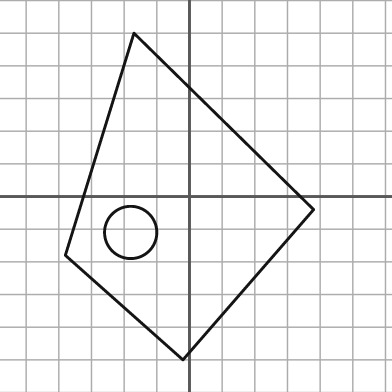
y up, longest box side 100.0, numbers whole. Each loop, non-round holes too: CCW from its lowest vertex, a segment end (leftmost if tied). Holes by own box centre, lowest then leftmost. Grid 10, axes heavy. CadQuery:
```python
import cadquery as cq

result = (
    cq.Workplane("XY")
    .moveTo(-2.0, -50.0)
    .lineTo(38.0, -4.0)
    .lineTo(-17.0, 50.0)
    .lineTo(-38.0, -18.0)
    .close()
    .moveTo(-18.0, -11.0)
    .circle(8.0)
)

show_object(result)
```